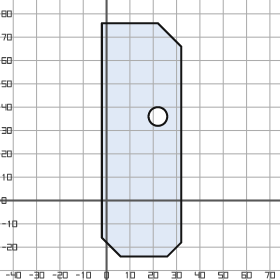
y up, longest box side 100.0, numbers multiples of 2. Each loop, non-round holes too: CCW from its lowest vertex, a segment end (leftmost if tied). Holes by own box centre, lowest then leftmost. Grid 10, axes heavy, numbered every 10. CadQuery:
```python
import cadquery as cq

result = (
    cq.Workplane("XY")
    .moveTo(6.0, -24.0)
    .lineTo(26.0, -24.0)
    .lineTo(32.0, -18.0)
    .lineTo(32.0, 66.0)
    .lineTo(22.0, 76.0)
    .lineTo(-2.0, 76.0)
    .lineTo(-2.0, -16.0)
    .close()
    .moveTo(22.0, 36.0)
    .circle(4.0)
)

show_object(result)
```